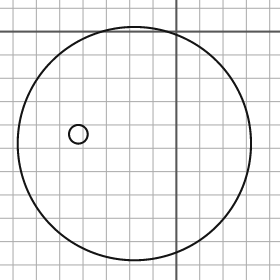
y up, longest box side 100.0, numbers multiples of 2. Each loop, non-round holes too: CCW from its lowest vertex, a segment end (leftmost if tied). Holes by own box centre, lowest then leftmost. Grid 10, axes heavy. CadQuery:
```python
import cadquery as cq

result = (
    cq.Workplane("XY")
    .moveTo(-18.0, -48.0)
    .circle(50.0)
    .moveTo(-42.0, -44.0)
    .circle(4.0)
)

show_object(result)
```